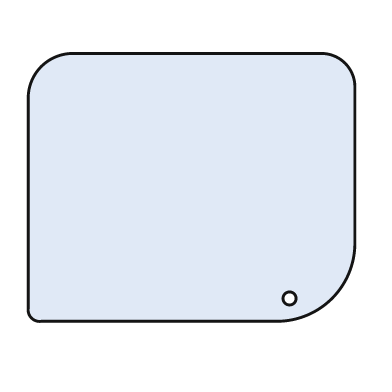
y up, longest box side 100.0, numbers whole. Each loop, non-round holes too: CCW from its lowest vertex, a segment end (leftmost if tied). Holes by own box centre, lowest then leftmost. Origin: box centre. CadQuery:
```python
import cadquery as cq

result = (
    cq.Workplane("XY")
    .moveTo(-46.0, -41.0)
    .lineTo(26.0, -41.0)
    .threePointArc((43.0, -34.0), (50.0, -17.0))
    .lineTo(50.0, 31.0)
    .threePointArc((47.0, 38.0), (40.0, 41.0))
    .lineTo(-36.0, 41.0)
    .threePointArc((-46.0, 37.0), (-50.0, 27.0))
    .lineTo(-50.0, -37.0)
    .threePointArc((-49.0, -40.0), (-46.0, -41.0))
    .close()
    .moveTo(30.0, -34.0)
    .circle(2.0)
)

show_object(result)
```